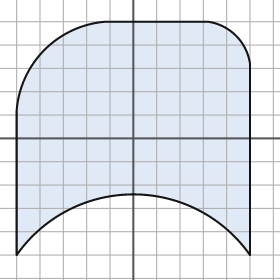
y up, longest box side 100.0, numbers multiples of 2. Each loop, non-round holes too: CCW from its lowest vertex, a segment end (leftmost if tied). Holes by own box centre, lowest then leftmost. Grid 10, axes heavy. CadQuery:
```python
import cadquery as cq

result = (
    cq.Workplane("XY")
    .moveTo(-50.0, -50.0)
    .threePointArc((0.0, -24.0), (50.0, -50.0))
    .lineTo(50.0, 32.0)
    .threePointArc((44.0, 44.0), (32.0, 50.0))
    .lineTo(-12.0, 50.0)
    .threePointArc((-38.0, 38.0), (-50.0, 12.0))
    .close()
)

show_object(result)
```